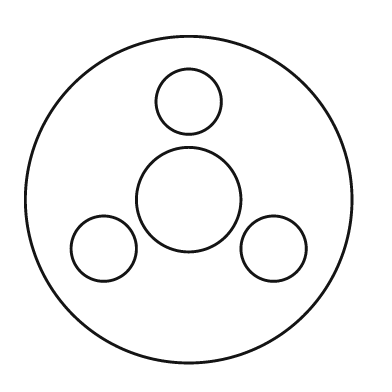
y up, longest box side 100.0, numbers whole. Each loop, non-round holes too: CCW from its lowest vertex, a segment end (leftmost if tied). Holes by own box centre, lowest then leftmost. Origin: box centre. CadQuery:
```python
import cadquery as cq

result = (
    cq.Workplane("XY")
    .moveTo(0.0, 0.0)
    .circle(50.0)
    .moveTo(-26.0, -15.0)
    .circle(10.0)
    .moveTo(26.0, -15.0)
    .circle(10.0)
    .moveTo(0.0, 0.0)
    .circle(16.0)
    .moveTo(0.0, 30.0)
    .circle(10.0)
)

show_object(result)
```